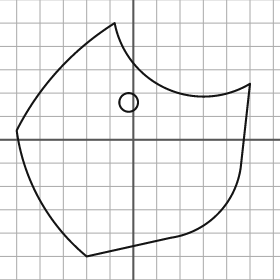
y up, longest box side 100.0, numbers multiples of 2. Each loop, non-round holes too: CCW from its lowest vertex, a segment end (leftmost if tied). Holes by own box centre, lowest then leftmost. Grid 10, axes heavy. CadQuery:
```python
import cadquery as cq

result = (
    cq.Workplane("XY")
    .moveTo(-20.0, -50.0)
    .lineTo(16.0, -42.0)
    .threePointArc((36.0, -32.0), (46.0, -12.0))
    .lineTo(50.0, 24.0)
    .threePointArc((14.0, 22.0), (-8.0, 50.0))
    .threePointArc((-32.0, 30.0), (-50.0, 4.0))
    .threePointArc((-40.0, -26.0), (-20.0, -50.0))
    .close()
    .moveTo(-2.0, 16.0)
    .circle(4.0)
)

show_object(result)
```